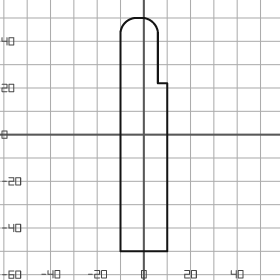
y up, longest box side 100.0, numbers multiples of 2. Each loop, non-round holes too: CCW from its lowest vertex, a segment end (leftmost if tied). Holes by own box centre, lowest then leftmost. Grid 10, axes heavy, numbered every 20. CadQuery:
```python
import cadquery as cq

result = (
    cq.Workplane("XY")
    .moveTo(-10.0, -50.0)
    .lineTo(10.0, -50.0)
    .lineTo(10.0, 22.0)
    .lineTo(6.0, 22.0)
    .lineTo(6.0, 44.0)
    .threePointArc((4.0, 48.0), (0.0, 50.0))
    .lineTo(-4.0, 50.0)
    .threePointArc((-8.0, 48.0), (-10.0, 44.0))
    .close()
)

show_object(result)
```